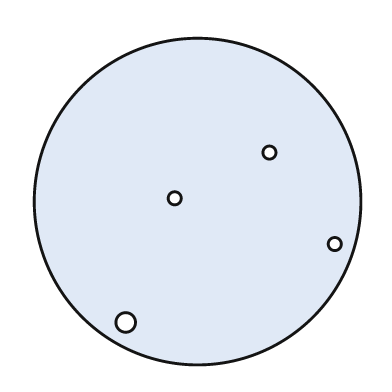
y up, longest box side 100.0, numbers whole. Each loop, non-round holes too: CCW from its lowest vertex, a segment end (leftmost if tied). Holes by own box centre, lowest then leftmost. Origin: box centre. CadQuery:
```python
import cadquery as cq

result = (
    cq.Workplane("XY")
    .moveTo(0.0, 0.0)
    .circle(50.0)
    .moveTo(-22.0, -37.0)
    .circle(3.0)
    .moveTo(42.0, -13.0)
    .circle(2.0)
    .moveTo(-7.0, 1.0)
    .circle(2.0)
    .moveTo(22.0, 15.0)
    .circle(2.0)
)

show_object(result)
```